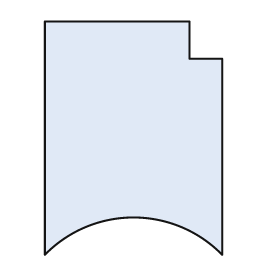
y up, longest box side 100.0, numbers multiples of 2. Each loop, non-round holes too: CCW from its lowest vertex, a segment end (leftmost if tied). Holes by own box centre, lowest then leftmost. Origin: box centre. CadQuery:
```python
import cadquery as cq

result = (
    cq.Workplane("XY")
    .moveTo(-38.0, -50.0)
    .threePointArc((0.0, -34.0), (38.0, -50.0))
    .lineTo(38.0, 34.0)
    .lineTo(24.0, 34.0)
    .lineTo(24.0, 50.0)
    .lineTo(-38.0, 50.0)
    .close()
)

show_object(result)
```